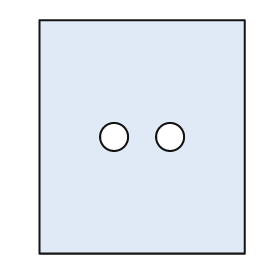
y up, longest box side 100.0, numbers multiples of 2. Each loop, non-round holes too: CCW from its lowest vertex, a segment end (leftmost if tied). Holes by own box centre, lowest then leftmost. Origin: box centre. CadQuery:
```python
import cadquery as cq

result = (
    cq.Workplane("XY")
    .moveTo(-44.0, -50.0)
    .lineTo(44.0, -50.0)
    .lineTo(44.0, 50.0)
    .lineTo(-44.0, 50.0)
    .close()
    .moveTo(-12.0, 0.0)
    .circle(6.0)
    .moveTo(12.0, 0.0)
    .circle(6.0)
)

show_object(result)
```